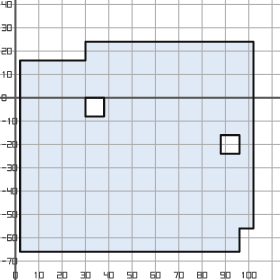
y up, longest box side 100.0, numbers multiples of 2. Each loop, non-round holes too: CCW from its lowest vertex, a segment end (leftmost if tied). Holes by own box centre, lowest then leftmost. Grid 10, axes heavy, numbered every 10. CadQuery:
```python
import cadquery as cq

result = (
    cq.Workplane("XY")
    .moveTo(2.0, -66.0)
    .lineTo(96.0, -66.0)
    .lineTo(96.0, -56.0)
    .lineTo(102.0, -56.0)
    .lineTo(102.0, 24.0)
    .lineTo(30.0, 24.0)
    .lineTo(30.0, 16.0)
    .lineTo(2.0, 16.0)
    .close()
    .moveTo(88.0, -24.0)
    .lineTo(96.0, -24.0)
    .lineTo(96.0, -16.0)
    .lineTo(88.0, -16.0)
    .close()
    .moveTo(30.0, -8.0)
    .lineTo(38.0, -8.0)
    .lineTo(38.0, 0.0)
    .lineTo(30.0, 0.0)
    .close()
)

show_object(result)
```